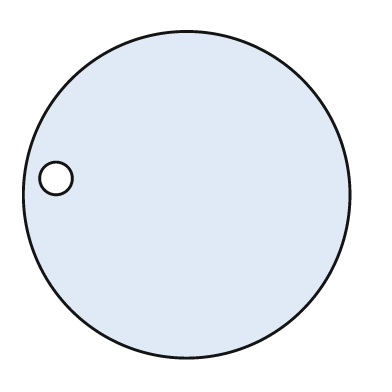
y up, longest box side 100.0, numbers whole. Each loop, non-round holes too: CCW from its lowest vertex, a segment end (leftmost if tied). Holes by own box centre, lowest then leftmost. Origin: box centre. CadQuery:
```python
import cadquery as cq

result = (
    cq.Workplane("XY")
    .moveTo(0.0, 0.0)
    .circle(50.0)
    .moveTo(-40.0, 5.0)
    .circle(5.0)
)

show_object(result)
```